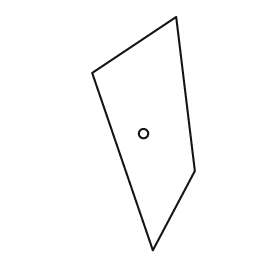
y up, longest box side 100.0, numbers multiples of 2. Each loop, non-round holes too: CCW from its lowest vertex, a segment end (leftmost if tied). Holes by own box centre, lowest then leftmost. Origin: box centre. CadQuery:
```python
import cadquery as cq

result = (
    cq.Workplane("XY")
    .moveTo(4.0, -50.0)
    .lineTo(22.0, -16.0)
    .lineTo(14.0, 50.0)
    .lineTo(-22.0, 26.0)
    .close()
    .moveTo(0.0, 0.0)
    .circle(2.0)
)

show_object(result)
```